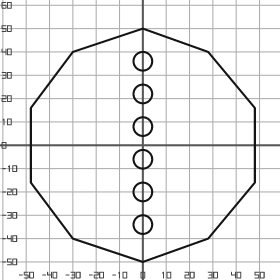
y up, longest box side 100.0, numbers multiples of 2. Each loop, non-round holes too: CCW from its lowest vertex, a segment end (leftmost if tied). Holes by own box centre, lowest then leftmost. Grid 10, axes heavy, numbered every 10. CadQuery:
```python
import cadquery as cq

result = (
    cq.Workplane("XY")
    .moveTo(0.0, -50.0)
    .lineTo(28.0, -40.0)
    .lineTo(48.0, -16.0)
    .lineTo(48.0, 16.0)
    .lineTo(28.0, 40.0)
    .lineTo(0.0, 50.0)
    .lineTo(-30.0, 40.0)
    .lineTo(-48.0, 16.0)
    .lineTo(-48.0, -16.0)
    .lineTo(-30.0, -40.0)
    .close()
    .moveTo(0.0, -34.0)
    .circle(4.0)
    .moveTo(0.0, -20.0)
    .circle(4.0)
    .moveTo(0.0, -6.0)
    .circle(4.0)
    .moveTo(0.0, 8.0)
    .circle(4.0)
    .moveTo(0.0, 22.0)
    .circle(4.0)
    .moveTo(0.0, 36.0)
    .circle(4.0)
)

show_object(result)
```